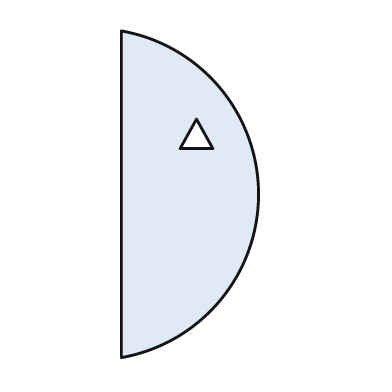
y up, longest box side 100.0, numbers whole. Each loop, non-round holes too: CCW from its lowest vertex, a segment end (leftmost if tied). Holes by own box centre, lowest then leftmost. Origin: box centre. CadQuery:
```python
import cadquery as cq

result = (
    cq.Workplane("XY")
    .moveTo(-21.0, -50.0)
    .threePointArc((21.0, 0.0), (-21.0, 50.0))
    .close()
    .moveTo(-3.0, 14.0)
    .lineTo(7.0, 14.0)
    .lineTo(2.0, 23.0)
    .close()
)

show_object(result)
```